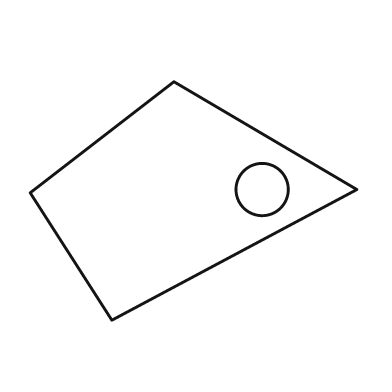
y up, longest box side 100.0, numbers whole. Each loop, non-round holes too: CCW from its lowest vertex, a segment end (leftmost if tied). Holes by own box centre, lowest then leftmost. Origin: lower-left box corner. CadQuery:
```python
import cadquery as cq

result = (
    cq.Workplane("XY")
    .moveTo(25.0, 0.0)
    .lineTo(100.0, 40.0)
    .lineTo(44.0, 73.0)
    .lineTo(0.0, 39.0)
    .close()
    .moveTo(71.0, 40.0)
    .circle(8.0)
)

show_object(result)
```